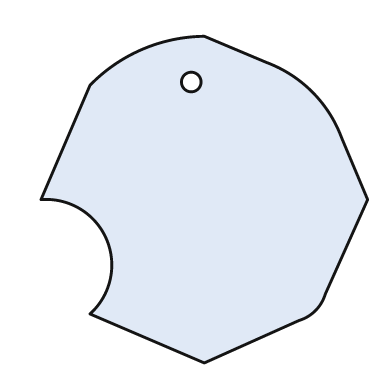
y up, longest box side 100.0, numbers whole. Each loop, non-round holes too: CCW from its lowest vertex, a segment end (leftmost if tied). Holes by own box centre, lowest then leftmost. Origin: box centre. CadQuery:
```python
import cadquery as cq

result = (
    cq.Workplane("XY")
    .moveTo(0.0, -50.0)
    .lineTo(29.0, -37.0)
    .threePointArc((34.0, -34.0), (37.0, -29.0))
    .lineTo(50.0, 0.0)
    .lineTo(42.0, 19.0)
    .threePointArc((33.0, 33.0), (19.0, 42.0))
    .lineTo(0.0, 50.0)
    .threePointArc((-19.0, 46.0), (-35.0, 35.0))
    .lineTo(-50.0, 0.0)
    .threePointArc((-30.0, -12.0), (-35.0, -35.0))
    .close()
    .moveTo(-4.0, 36.0)
    .circle(3.0)
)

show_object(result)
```